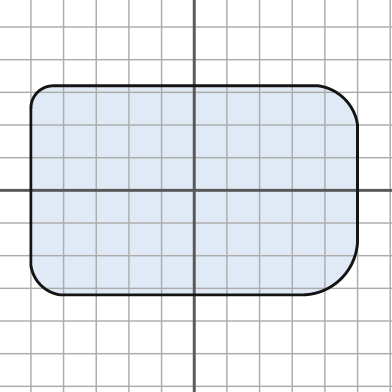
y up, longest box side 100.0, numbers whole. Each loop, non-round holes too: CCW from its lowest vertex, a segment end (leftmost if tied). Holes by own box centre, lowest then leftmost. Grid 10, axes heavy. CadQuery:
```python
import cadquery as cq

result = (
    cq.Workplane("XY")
    .moveTo(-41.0, -32.0)
    .lineTo(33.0, -32.0)
    .threePointArc((45.0, -27.0), (50.0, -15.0))
    .lineTo(50.0, 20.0)
    .threePointArc((46.0, 28.0), (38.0, 32.0))
    .lineTo(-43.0, 32.0)
    .threePointArc((-48.0, 30.0), (-50.0, 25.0))
    .lineTo(-50.0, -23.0)
    .threePointArc((-47.0, -29.0), (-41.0, -32.0))
    .close()
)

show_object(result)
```